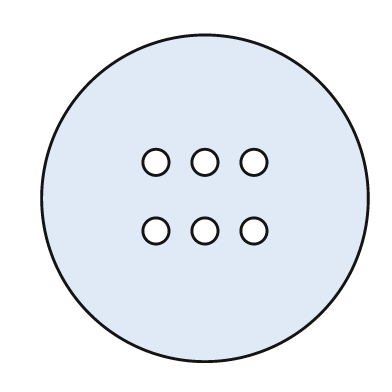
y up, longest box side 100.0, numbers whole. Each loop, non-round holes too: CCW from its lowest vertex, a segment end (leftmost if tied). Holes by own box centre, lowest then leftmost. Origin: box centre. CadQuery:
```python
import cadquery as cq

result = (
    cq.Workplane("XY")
    .moveTo(0.0, 0.0)
    .circle(50.0)
    .moveTo(-15.0, -10.0)
    .circle(4.0)
    .moveTo(0.0, -10.0)
    .circle(4.0)
    .moveTo(15.0, -10.0)
    .circle(4.0)
    .moveTo(-15.0, 11.0)
    .circle(4.0)
    .moveTo(0.0, 11.0)
    .circle(4.0)
    .moveTo(15.0, 11.0)
    .circle(4.0)
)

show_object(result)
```